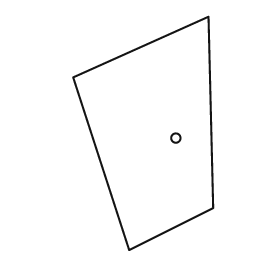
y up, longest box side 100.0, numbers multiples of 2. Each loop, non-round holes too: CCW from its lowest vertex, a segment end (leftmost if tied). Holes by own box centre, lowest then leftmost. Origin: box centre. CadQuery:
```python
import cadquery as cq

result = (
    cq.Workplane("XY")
    .moveTo(-6.0, -50.0)
    .lineTo(30.0, -32.0)
    .lineTo(28.0, 50.0)
    .lineTo(-30.0, 24.0)
    .close()
    .moveTo(14.0, -2.0)
    .circle(2.0)
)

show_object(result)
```